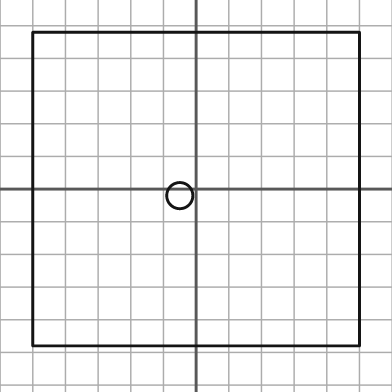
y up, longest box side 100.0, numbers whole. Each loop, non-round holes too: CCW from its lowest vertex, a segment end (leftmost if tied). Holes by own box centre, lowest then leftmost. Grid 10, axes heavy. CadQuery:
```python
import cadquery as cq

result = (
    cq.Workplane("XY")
    .moveTo(-50.0, -48.0)
    .lineTo(50.0, -48.0)
    .lineTo(50.0, 48.0)
    .lineTo(-50.0, 48.0)
    .close()
    .moveTo(-5.0, -2.0)
    .circle(4.0)
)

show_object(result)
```